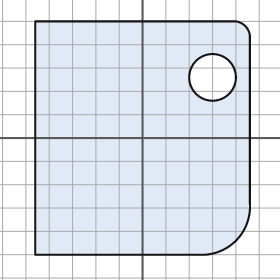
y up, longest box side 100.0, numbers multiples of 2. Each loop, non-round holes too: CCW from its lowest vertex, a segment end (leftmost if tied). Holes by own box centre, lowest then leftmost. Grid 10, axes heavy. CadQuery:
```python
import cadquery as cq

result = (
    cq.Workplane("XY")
    .moveTo(-46.0, -50.0)
    .lineTo(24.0, -50.0)
    .threePointArc((40.0, -44.0), (46.0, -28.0))
    .lineTo(46.0, 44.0)
    .threePointArc((44.0, 48.0), (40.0, 50.0))
    .lineTo(-46.0, 50.0)
    .close()
    .moveTo(30.0, 26.0)
    .circle(10.0)
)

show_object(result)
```